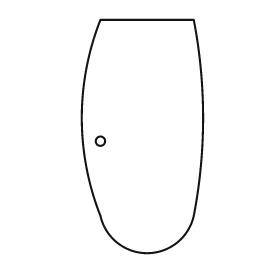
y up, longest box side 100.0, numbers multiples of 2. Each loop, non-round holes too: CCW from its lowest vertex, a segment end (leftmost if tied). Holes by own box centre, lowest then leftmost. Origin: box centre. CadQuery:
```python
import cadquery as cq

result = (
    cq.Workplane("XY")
    .moveTo(-18.0, -34.0)
    .threePointArc((2.0, -50.0), (22.0, -34.0))
    .threePointArc((26.0, 8.0), (22.0, 50.0))
    .lineTo(-18.0, 50.0)
    .threePointArc((-26.0, 8.0), (-18.0, -34.0))
    .close()
    .moveTo(-18.0, -2.0)
    .circle(2.0)
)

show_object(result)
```